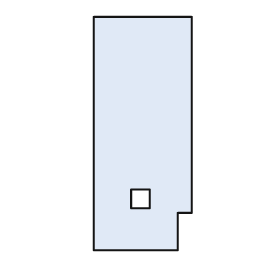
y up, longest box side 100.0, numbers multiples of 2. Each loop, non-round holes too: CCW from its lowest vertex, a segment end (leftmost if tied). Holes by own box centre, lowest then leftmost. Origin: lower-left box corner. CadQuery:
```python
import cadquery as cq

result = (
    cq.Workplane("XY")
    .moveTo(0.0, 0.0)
    .lineTo(36.0, 0.0)
    .lineTo(36.0, 16.0)
    .lineTo(42.0, 16.0)
    .lineTo(42.0, 100.0)
    .lineTo(0.0, 100.0)
    .close()
    .moveTo(16.0, 18.0)
    .lineTo(24.0, 18.0)
    .lineTo(24.0, 26.0)
    .lineTo(16.0, 26.0)
    .close()
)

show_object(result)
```